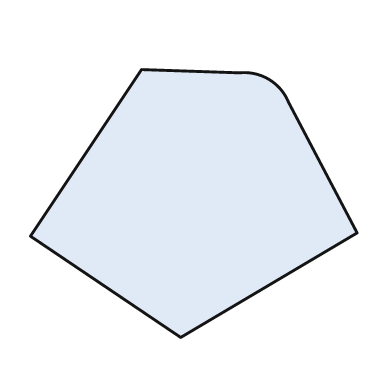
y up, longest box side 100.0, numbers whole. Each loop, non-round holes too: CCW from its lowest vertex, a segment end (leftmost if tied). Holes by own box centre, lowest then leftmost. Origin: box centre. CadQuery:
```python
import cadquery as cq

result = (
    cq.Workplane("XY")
    .moveTo(-4.0, -41.0)
    .lineTo(50.0, -9.0)
    .lineTo(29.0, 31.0)
    .threePointArc((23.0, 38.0), (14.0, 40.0))
    .lineTo(-16.0, 41.0)
    .lineTo(-50.0, -10.0)
    .close()
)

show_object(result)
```